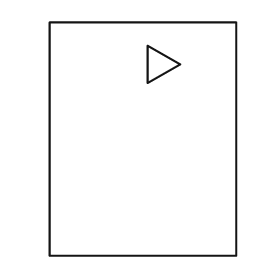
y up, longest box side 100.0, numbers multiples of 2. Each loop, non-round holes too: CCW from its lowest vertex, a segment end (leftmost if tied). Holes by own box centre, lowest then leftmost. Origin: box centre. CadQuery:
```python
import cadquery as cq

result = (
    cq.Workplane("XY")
    .moveTo(-40.0, -50.0)
    .lineTo(40.0, -50.0)
    .lineTo(40.0, 50.0)
    .lineTo(-40.0, 50.0)
    .close()
    .moveTo(2.0, 24.0)
    .lineTo(16.0, 32.0)
    .lineTo(2.0, 40.0)
    .close()
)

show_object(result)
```